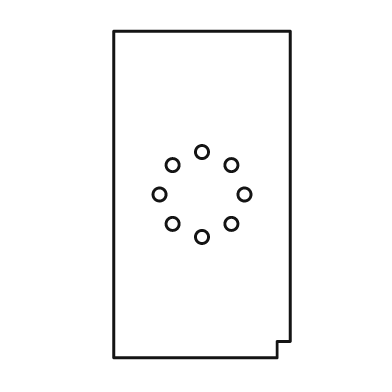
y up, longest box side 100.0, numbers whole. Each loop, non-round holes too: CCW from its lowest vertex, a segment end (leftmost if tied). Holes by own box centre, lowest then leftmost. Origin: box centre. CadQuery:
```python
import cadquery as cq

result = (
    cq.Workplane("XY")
    .moveTo(-27.0, -50.0)
    .lineTo(23.0, -50.0)
    .lineTo(23.0, -45.0)
    .lineTo(27.0, -45.0)
    .lineTo(27.0, 50.0)
    .lineTo(-27.0, 50.0)
    .close()
    .moveTo(0.0, -13.0)
    .circle(2.0)
    .moveTo(-9.0, -9.0)
    .circle(2.0)
    .moveTo(9.0, -9.0)
    .circle(2.0)
    .moveTo(-13.0, 0.0)
    .circle(2.0)
    .moveTo(13.0, 0.0)
    .circle(2.0)
    .moveTo(-9.0, 9.0)
    .circle(2.0)
    .moveTo(9.0, 9.0)
    .circle(2.0)
    .moveTo(0.0, 13.0)
    .circle(2.0)
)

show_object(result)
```